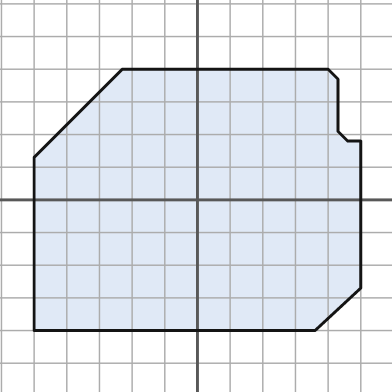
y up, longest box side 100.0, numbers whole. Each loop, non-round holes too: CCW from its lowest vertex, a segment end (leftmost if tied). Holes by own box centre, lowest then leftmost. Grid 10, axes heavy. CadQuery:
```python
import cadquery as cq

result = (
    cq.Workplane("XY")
    .moveTo(-50.0, -40.0)
    .lineTo(36.0, -40.0)
    .lineTo(50.0, -27.0)
    .lineTo(50.0, 18.0)
    .lineTo(46.0, 18.0)
    .lineTo(43.0, 21.0)
    .lineTo(43.0, 37.0)
    .lineTo(40.0, 40.0)
    .lineTo(-23.0, 40.0)
    .lineTo(-50.0, 13.0)
    .close()
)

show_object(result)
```